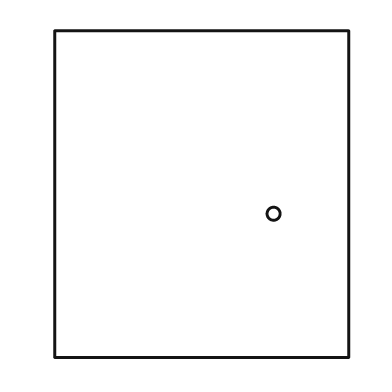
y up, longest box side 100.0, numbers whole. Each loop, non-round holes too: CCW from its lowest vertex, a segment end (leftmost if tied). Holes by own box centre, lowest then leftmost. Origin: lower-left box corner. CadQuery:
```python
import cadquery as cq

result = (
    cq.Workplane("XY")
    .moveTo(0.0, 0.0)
    .lineTo(90.0, 0.0)
    .lineTo(90.0, 100.0)
    .lineTo(0.0, 100.0)
    .close()
    .moveTo(67.0, 44.0)
    .circle(2.0)
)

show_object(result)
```